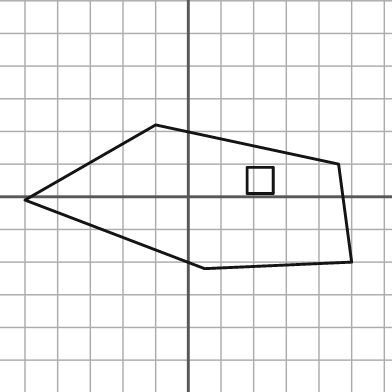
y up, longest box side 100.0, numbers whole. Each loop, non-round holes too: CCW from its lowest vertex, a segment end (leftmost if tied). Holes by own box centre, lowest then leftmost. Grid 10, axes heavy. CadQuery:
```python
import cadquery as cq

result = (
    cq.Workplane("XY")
    .moveTo(5.0, -22.0)
    .lineTo(50.0, -20.0)
    .lineTo(46.0, 10.0)
    .lineTo(-10.0, 22.0)
    .lineTo(-50.0, -1.0)
    .close()
    .moveTo(18.0, 1.0)
    .lineTo(26.0, 1.0)
    .lineTo(26.0, 9.0)
    .lineTo(18.0, 9.0)
    .close()
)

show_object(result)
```